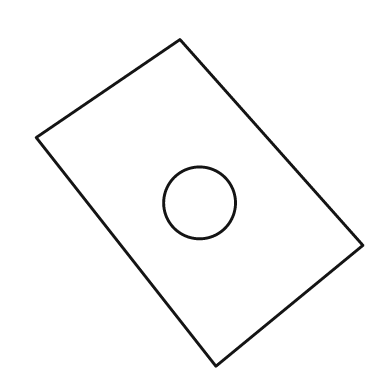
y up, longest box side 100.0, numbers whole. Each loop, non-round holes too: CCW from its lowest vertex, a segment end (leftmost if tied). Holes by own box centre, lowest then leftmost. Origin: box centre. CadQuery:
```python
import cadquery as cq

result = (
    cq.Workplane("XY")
    .moveTo(5.0, -50.0)
    .lineTo(50.0, -13.0)
    .lineTo(-6.0, 50.0)
    .lineTo(-50.0, 20.0)
    .close()
    .moveTo(0.0, 0.0)
    .circle(11.0)
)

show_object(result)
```